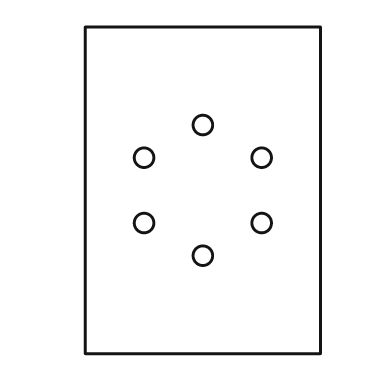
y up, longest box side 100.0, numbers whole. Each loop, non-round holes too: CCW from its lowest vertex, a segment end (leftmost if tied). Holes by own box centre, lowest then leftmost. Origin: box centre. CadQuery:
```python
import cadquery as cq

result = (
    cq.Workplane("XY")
    .moveTo(-36.0, -50.0)
    .lineTo(36.0, -50.0)
    .lineTo(36.0, 50.0)
    .lineTo(-36.0, 50.0)
    .close()
    .moveTo(0.0, -20.0)
    .circle(3.0)
    .moveTo(-18.0, -10.0)
    .circle(3.0)
    .moveTo(18.0, -10.0)
    .circle(3.0)
    .moveTo(-18.0, 10.0)
    .circle(3.0)
    .moveTo(18.0, 10.0)
    .circle(3.0)
    .moveTo(0.0, 20.0)
    .circle(3.0)
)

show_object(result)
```